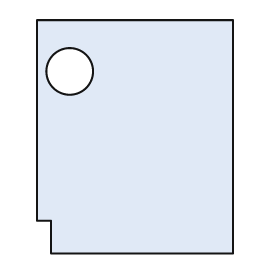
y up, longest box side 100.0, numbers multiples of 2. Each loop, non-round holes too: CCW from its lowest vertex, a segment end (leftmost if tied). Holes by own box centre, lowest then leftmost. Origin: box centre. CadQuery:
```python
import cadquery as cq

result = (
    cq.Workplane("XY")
    .moveTo(-36.0, -50.0)
    .lineTo(42.0, -50.0)
    .lineTo(42.0, 50.0)
    .lineTo(-42.0, 50.0)
    .lineTo(-42.0, -36.0)
    .lineTo(-36.0, -36.0)
    .close()
    .moveTo(-28.0, 28.0)
    .circle(10.0)
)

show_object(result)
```